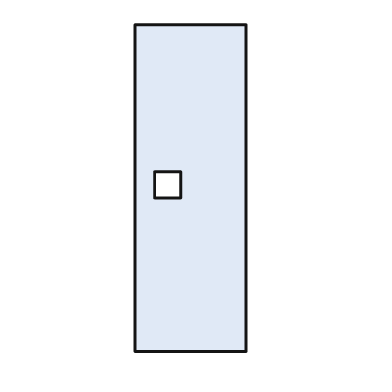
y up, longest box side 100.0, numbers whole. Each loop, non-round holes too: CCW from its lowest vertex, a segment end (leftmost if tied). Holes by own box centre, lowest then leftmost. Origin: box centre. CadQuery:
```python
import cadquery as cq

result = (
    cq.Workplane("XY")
    .moveTo(-17.0, -50.0)
    .lineTo(17.0, -50.0)
    .lineTo(17.0, 50.0)
    .lineTo(-17.0, 50.0)
    .close()
    .moveTo(-11.0, -3.0)
    .lineTo(-3.0, -3.0)
    .lineTo(-3.0, 5.0)
    .lineTo(-11.0, 5.0)
    .close()
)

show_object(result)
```